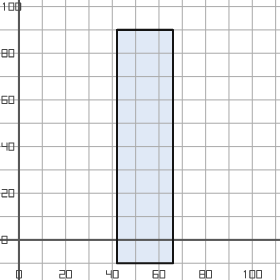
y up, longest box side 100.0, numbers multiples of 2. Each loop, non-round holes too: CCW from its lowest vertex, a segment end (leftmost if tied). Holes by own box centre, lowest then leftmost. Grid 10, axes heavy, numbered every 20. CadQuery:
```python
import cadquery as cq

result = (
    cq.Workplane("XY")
    .moveTo(42.0, -10.0)
    .lineTo(66.0, -10.0)
    .lineTo(66.0, 90.0)
    .lineTo(42.0, 90.0)
    .close()
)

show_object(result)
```